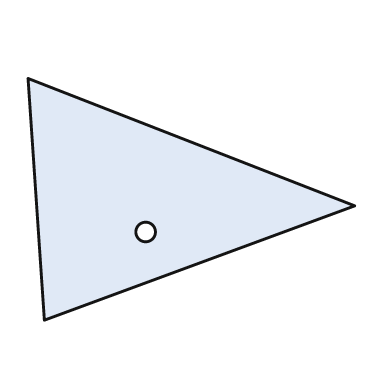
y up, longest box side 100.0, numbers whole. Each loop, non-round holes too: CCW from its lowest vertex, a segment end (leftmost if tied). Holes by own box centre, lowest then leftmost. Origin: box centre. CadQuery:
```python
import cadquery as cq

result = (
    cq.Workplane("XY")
    .moveTo(-45.0, -37.0)
    .lineTo(50.0, -2.0)
    .lineTo(-50.0, 37.0)
    .close()
    .moveTo(-14.0, -10.0)
    .circle(3.0)
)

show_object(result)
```